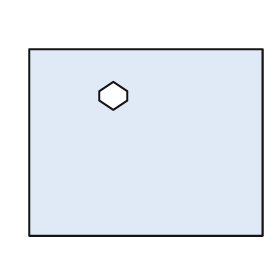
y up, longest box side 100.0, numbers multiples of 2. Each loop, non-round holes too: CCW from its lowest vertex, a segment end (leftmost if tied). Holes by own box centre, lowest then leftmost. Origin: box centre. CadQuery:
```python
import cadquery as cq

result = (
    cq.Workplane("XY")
    .moveTo(-50.0, -40.0)
    .lineTo(50.0, -40.0)
    .lineTo(50.0, 40.0)
    .lineTo(-50.0, 40.0)
    .close()
    .moveTo(-14.0, 14.0)
    .lineTo(-8.0, 18.0)
    .lineTo(-8.0, 22.0)
    .lineTo(-14.0, 26.0)
    .lineTo(-20.0, 22.0)
    .lineTo(-20.0, 18.0)
    .close()
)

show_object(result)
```